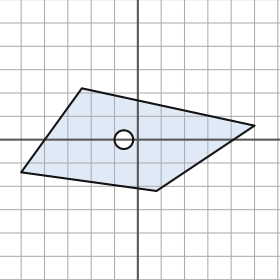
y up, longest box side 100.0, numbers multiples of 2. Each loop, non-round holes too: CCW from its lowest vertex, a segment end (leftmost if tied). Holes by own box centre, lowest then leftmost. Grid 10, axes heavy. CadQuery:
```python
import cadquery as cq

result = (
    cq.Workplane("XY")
    .moveTo(8.0, -22.0)
    .lineTo(50.0, 6.0)
    .lineTo(-24.0, 22.0)
    .lineTo(-50.0, -14.0)
    .close()
    .moveTo(-6.0, 0.0)
    .circle(4.0)
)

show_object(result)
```